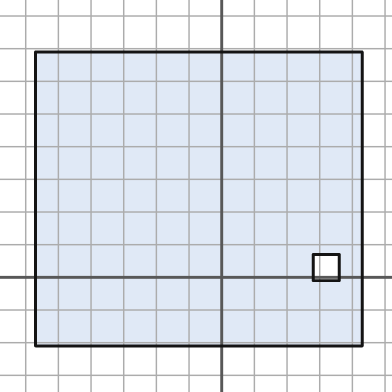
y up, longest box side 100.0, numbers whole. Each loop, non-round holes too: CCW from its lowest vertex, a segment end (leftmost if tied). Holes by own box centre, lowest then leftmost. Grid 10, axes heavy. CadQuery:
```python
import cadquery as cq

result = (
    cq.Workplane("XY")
    .moveTo(-57.0, -21.0)
    .lineTo(43.0, -21.0)
    .lineTo(43.0, 69.0)
    .lineTo(-57.0, 69.0)
    .close()
    .moveTo(28.0, -1.0)
    .lineTo(36.0, -1.0)
    .lineTo(36.0, 7.0)
    .lineTo(28.0, 7.0)
    .close()
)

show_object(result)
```